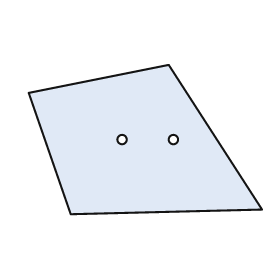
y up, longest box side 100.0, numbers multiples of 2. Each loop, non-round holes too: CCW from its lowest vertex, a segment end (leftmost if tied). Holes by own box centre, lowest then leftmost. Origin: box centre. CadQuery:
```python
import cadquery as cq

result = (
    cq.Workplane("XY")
    .moveTo(-32.0, -32.0)
    .lineTo(50.0, -30.0)
    .lineTo(10.0, 32.0)
    .lineTo(-50.0, 20.0)
    .close()
    .moveTo(-10.0, 0.0)
    .circle(2.0)
    .moveTo(12.0, 0.0)
    .circle(2.0)
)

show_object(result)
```